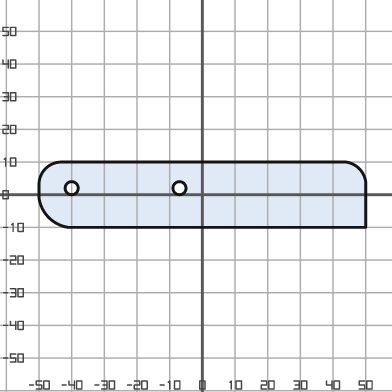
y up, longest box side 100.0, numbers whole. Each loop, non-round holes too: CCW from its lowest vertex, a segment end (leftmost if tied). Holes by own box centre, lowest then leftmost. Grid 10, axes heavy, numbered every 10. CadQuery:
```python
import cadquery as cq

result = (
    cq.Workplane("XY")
    .moveTo(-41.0, -10.0)
    .lineTo(50.0, -10.0)
    .lineTo(50.0, 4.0)
    .threePointArc((48.0, 8.0), (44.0, 10.0))
    .lineTo(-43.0, 10.0)
    .threePointArc((-48.0, 8.0), (-50.0, 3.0))
    .lineTo(-50.0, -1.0)
    .threePointArc((-47.0, -7.0), (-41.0, -10.0))
    .close()
    .moveTo(-40.0, 2.0)
    .circle(2.0)
    .moveTo(-7.0, 2.0)
    .circle(2.0)
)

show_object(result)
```